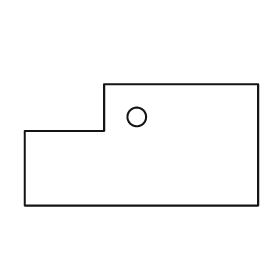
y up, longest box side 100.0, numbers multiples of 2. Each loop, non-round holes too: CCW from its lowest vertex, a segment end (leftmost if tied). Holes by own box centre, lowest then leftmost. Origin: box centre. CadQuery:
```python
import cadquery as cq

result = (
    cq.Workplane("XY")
    .moveTo(-50.0, -26.0)
    .lineTo(50.0, -26.0)
    .lineTo(50.0, 26.0)
    .lineTo(-16.0, 26.0)
    .lineTo(-16.0, 6.0)
    .lineTo(-50.0, 6.0)
    .close()
    .moveTo(-2.0, 12.0)
    .circle(4.0)
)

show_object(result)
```